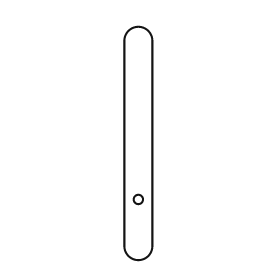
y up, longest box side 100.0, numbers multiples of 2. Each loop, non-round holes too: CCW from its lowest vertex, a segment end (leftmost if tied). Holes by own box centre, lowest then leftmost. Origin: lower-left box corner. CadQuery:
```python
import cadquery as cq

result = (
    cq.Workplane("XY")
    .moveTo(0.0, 6.0)
    .threePointArc((6.0, 0.0), (12.0, 6.0))
    .lineTo(12.0, 94.0)
    .threePointArc((6.0, 100.0), (0.0, 94.0))
    .close()
    .moveTo(6.0, 26.0)
    .circle(2.0)
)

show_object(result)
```